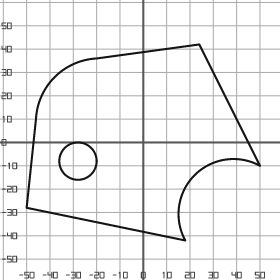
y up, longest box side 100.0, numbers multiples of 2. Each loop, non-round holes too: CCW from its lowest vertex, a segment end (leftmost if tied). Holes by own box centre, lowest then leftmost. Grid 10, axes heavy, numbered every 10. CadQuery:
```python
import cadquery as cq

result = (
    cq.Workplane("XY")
    .moveTo(18.0, -42.0)
    .threePointArc((22.0, -14.0), (50.0, -10.0))
    .lineTo(24.0, 42.0)
    .lineTo(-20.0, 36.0)
    .threePointArc((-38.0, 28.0), (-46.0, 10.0))
    .lineTo(-50.0, -28.0)
    .close()
    .moveTo(-28.0, -8.0)
    .circle(8.0)
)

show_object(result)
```